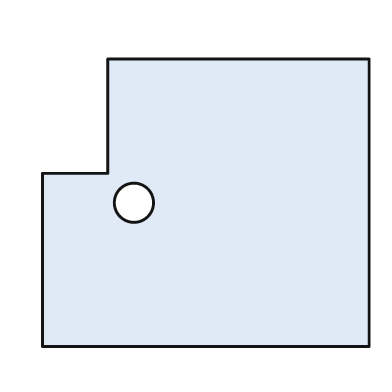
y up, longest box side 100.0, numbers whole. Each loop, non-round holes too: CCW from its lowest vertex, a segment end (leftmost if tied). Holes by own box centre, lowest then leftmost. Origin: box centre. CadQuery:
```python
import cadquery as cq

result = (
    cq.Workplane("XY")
    .moveTo(-50.0, -44.0)
    .lineTo(50.0, -44.0)
    .lineTo(50.0, 44.0)
    .lineTo(-30.0, 44.0)
    .lineTo(-30.0, 9.0)
    .lineTo(-50.0, 9.0)
    .close()
    .moveTo(-22.0, 0.0)
    .circle(6.0)
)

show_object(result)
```